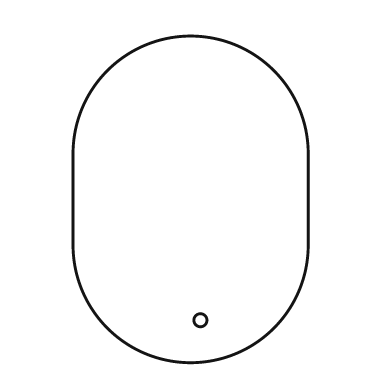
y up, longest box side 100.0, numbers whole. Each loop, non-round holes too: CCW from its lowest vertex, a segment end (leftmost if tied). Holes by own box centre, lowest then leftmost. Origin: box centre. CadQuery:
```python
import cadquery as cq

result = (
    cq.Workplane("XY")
    .moveTo(-36.0, -14.0)
    .threePointArc((0.0, -50.0), (36.0, -14.0))
    .lineTo(36.0, 14.0)
    .threePointArc((0.0, 50.0), (-36.0, 14.0))
    .close()
    .moveTo(3.0, -37.0)
    .circle(2.0)
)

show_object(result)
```